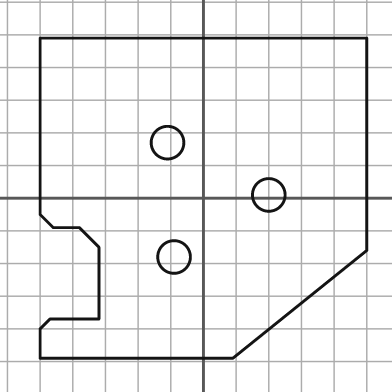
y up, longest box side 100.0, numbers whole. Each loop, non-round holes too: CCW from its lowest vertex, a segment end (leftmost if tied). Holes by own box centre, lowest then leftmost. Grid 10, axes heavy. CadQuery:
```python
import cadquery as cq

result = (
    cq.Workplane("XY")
    .moveTo(-50.0, -49.0)
    .lineTo(9.0, -49.0)
    .lineTo(50.0, -16.0)
    .lineTo(50.0, 49.0)
    .lineTo(-50.0, 49.0)
    .lineTo(-50.0, -5.0)
    .lineTo(-46.0, -9.0)
    .lineTo(-38.0, -9.0)
    .lineTo(-32.0, -15.0)
    .lineTo(-32.0, -37.0)
    .lineTo(-47.0, -37.0)
    .lineTo(-50.0, -40.0)
    .close()
    .moveTo(-9.0, -18.0)
    .circle(5.0)
    .moveTo(20.0, 1.0)
    .circle(5.0)
    .moveTo(-11.0, 17.0)
    .circle(5.0)
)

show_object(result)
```